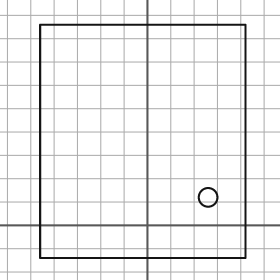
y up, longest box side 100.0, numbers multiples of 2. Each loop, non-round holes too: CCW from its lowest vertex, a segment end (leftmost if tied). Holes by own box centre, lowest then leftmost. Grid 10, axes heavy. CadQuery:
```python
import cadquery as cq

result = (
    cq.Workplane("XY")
    .moveTo(-46.0, -14.0)
    .lineTo(42.0, -14.0)
    .lineTo(42.0, 86.0)
    .lineTo(-46.0, 86.0)
    .close()
    .moveTo(26.0, 12.0)
    .circle(4.0)
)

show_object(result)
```